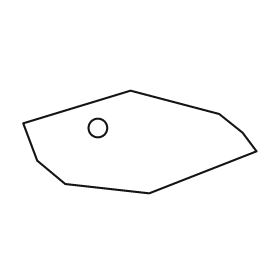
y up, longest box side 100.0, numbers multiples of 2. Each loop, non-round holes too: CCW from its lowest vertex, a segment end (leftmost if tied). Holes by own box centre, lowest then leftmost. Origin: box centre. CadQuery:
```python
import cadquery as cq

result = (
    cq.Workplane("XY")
    .moveTo(4.0, -22.0)
    .lineTo(50.0, -4.0)
    .lineTo(44.0, 4.0)
    .lineTo(34.0, 12.0)
    .lineTo(-4.0, 22.0)
    .lineTo(-50.0, 8.0)
    .lineTo(-44.0, -8.0)
    .lineTo(-32.0, -18.0)
    .close()
    .moveTo(-18.0, 6.0)
    .circle(4.0)
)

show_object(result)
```